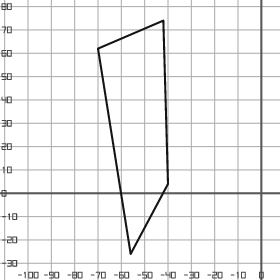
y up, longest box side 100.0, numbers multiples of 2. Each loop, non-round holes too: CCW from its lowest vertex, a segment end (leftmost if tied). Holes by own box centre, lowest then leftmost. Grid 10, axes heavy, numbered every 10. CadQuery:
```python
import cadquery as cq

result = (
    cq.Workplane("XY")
    .moveTo(-56.0, -26.0)
    .lineTo(-40.0, 4.0)
    .lineTo(-42.0, 74.0)
    .lineTo(-70.0, 62.0)
    .close()
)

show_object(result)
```